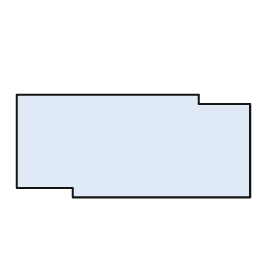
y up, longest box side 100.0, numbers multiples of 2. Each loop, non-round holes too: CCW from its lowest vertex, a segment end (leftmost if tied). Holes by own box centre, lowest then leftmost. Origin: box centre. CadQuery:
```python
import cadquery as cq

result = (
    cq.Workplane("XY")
    .moveTo(-26.0, -22.0)
    .lineTo(50.0, -22.0)
    .lineTo(50.0, 18.0)
    .lineTo(28.0, 18.0)
    .lineTo(28.0, 22.0)
    .lineTo(-50.0, 22.0)
    .lineTo(-50.0, -18.0)
    .lineTo(-26.0, -18.0)
    .close()
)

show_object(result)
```